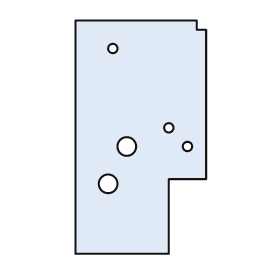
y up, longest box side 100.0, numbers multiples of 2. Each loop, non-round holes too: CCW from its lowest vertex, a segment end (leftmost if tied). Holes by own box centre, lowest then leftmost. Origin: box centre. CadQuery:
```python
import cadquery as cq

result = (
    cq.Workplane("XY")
    .moveTo(-28.0, -50.0)
    .lineTo(12.0, -50.0)
    .lineTo(12.0, -18.0)
    .lineTo(28.0, -18.0)
    .lineTo(28.0, 46.0)
    .lineTo(24.0, 46.0)
    .lineTo(24.0, 50.0)
    .lineTo(-28.0, 50.0)
    .close()
    .moveTo(-14.0, -20.0)
    .circle(4.0)
    .moveTo(-6.0, -4.0)
    .circle(4.0)
    .moveTo(20.0, -4.0)
    .circle(2.0)
    .moveTo(12.0, 4.0)
    .circle(2.0)
    .moveTo(-12.0, 38.0)
    .circle(2.0)
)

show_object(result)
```